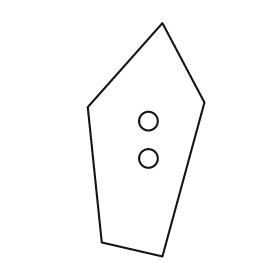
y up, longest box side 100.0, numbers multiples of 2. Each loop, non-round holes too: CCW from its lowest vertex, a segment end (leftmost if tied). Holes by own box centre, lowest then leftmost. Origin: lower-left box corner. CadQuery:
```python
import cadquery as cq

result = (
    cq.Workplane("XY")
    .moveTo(32.0, 0.0)
    .lineTo(50.0, 66.0)
    .lineTo(32.0, 100.0)
    .lineTo(0.0, 64.0)
    .lineTo(6.0, 6.0)
    .close()
    .moveTo(26.0, 42.0)
    .circle(4.0)
    .moveTo(26.0, 58.0)
    .circle(4.0)
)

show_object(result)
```